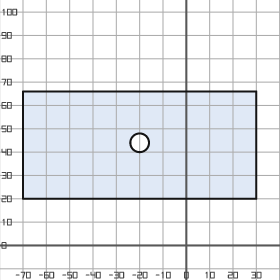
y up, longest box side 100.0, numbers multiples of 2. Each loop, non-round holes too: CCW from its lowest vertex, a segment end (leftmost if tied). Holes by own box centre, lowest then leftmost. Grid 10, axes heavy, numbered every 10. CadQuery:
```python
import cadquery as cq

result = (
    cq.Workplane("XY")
    .moveTo(-70.0, 20.0)
    .lineTo(30.0, 20.0)
    .lineTo(30.0, 66.0)
    .lineTo(-70.0, 66.0)
    .close()
    .moveTo(-20.0, 44.0)
    .circle(4.0)
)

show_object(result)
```